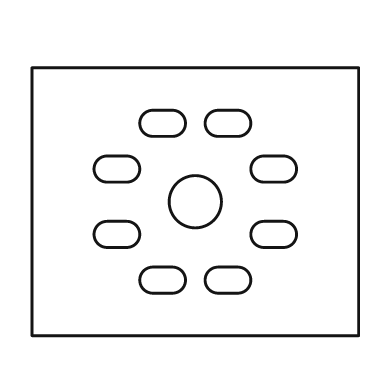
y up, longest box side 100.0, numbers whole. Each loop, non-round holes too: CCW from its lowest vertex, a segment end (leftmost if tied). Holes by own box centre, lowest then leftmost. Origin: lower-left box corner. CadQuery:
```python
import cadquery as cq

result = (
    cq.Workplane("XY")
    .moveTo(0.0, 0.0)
    .lineTo(100.0, 0.0)
    .lineTo(100.0, 82.0)
    .lineTo(0.0, 82.0)
    .close()
    .moveTo(37.0, 13.0)
    .lineTo(43.0, 13.0)
    .threePointArc((47.0, 17.0), (43.0, 21.0))
    .lineTo(37.0, 21.0)
    .threePointArc((33.0, 17.0), (37.0, 13.0))
    .close()
    .moveTo(57.0, 13.0)
    .lineTo(63.0, 13.0)
    .threePointArc((67.0, 17.0), (63.0, 21.0))
    .lineTo(57.0, 21.0)
    .threePointArc((53.0, 17.0), (57.0, 13.0))
    .close()
    .moveTo(23.0, 27.0)
    .lineTo(29.0, 27.0)
    .threePointArc((33.0, 31.0), (29.0, 35.0))
    .lineTo(23.0, 35.0)
    .threePointArc((19.0, 31.0), (23.0, 27.0))
    .close()
    .moveTo(71.0, 27.0)
    .lineTo(77.0, 27.0)
    .threePointArc((81.0, 31.0), (77.0, 35.0))
    .lineTo(71.0, 35.0)
    .threePointArc((67.0, 31.0), (71.0, 27.0))
    .close()
    .moveTo(50.0, 41.0)
    .circle(8.0)
    .moveTo(23.0, 47.0)
    .lineTo(29.0, 47.0)
    .threePointArc((33.0, 51.0), (29.0, 55.0))
    .lineTo(23.0, 55.0)
    .threePointArc((19.0, 51.0), (23.0, 47.0))
    .close()
    .moveTo(71.0, 47.0)
    .lineTo(77.0, 47.0)
    .threePointArc((81.0, 51.0), (77.0, 55.0))
    .lineTo(71.0, 55.0)
    .threePointArc((67.0, 51.0), (71.0, 47.0))
    .close()
    .moveTo(37.0, 61.0)
    .lineTo(43.0, 61.0)
    .threePointArc((47.0, 65.0), (43.0, 69.0))
    .lineTo(37.0, 69.0)
    .threePointArc((33.0, 65.0), (37.0, 61.0))
    .close()
    .moveTo(57.0, 61.0)
    .lineTo(63.0, 61.0)
    .threePointArc((67.0, 65.0), (63.0, 69.0))
    .lineTo(57.0, 69.0)
    .threePointArc((53.0, 65.0), (57.0, 61.0))
    .close()
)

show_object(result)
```